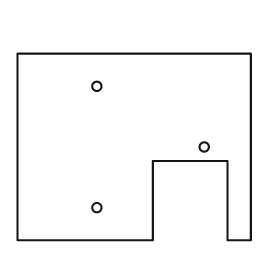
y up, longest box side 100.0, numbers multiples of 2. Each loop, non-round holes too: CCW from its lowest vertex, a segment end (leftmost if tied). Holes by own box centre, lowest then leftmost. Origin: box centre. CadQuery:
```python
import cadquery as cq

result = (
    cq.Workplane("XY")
    .moveTo(-50.0, -40.0)
    .lineTo(8.0, -40.0)
    .lineTo(8.0, -6.0)
    .lineTo(40.0, -6.0)
    .lineTo(40.0, -40.0)
    .lineTo(50.0, -40.0)
    .lineTo(50.0, 40.0)
    .lineTo(-50.0, 40.0)
    .close()
    .moveTo(-16.0, -26.0)
    .circle(2.0)
    .moveTo(30.0, 0.0)
    .circle(2.0)
    .moveTo(-16.0, 26.0)
    .circle(2.0)
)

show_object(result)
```